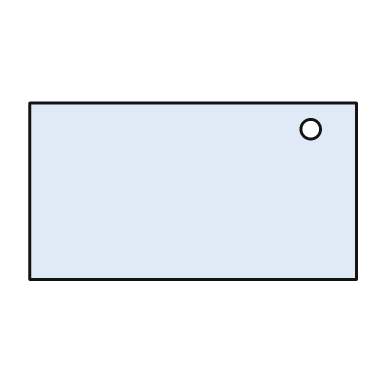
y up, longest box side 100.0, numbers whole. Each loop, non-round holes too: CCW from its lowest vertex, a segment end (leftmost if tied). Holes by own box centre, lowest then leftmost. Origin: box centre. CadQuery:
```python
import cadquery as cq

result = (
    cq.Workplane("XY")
    .moveTo(-50.0, -27.0)
    .lineTo(50.0, -27.0)
    .lineTo(50.0, 27.0)
    .lineTo(-50.0, 27.0)
    .close()
    .moveTo(36.0, 19.0)
    .circle(3.0)
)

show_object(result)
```